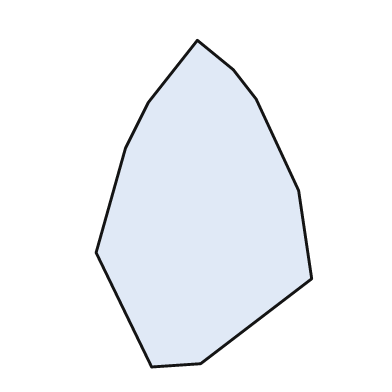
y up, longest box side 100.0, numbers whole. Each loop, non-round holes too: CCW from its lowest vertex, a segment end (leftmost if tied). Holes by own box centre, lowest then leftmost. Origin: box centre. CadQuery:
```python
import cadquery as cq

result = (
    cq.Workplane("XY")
    .moveTo(-16.0, -50.0)
    .lineTo(-1.0, -49.0)
    .lineTo(33.0, -23.0)
    .lineTo(29.0, 4.0)
    .lineTo(16.0, 32.0)
    .lineTo(9.0, 41.0)
    .lineTo(-2.0, 50.0)
    .lineTo(-17.0, 31.0)
    .lineTo(-24.0, 17.0)
    .lineTo(-33.0, -15.0)
    .close()
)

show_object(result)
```